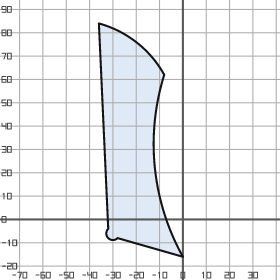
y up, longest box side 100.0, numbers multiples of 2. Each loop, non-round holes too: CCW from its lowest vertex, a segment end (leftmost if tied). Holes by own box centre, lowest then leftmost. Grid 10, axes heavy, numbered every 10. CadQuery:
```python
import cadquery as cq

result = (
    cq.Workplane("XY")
    .moveTo(0.0, -16.0)
    .threePointArc((-12.0, 22.0), (-8.0, 62.0))
    .threePointArc((-20.0, 76.0), (-36.0, 84.0))
    .lineTo(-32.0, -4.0)
    .threePointArc((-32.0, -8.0), (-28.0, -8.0))
    .close()
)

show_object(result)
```